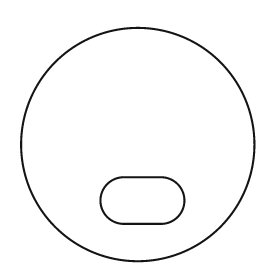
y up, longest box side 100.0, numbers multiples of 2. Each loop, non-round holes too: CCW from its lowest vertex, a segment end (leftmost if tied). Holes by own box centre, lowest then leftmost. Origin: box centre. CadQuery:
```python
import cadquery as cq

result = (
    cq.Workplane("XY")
    .moveTo(0.0, 0.0)
    .circle(50.0)
    .moveTo(-6.0, -34.0)
    .lineTo(10.0, -34.0)
    .threePointArc((20.0, -24.0), (10.0, -14.0))
    .lineTo(-6.0, -14.0)
    .threePointArc((-16.0, -24.0), (-6.0, -34.0))
    .close()
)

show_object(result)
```